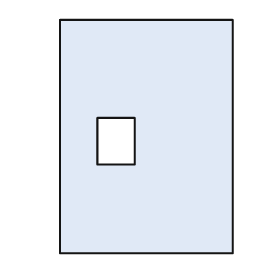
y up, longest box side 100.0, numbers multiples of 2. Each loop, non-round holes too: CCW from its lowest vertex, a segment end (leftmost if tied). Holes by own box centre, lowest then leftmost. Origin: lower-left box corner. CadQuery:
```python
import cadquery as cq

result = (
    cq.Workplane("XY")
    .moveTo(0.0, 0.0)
    .lineTo(74.0, 0.0)
    .lineTo(74.0, 100.0)
    .lineTo(0.0, 100.0)
    .close()
    .moveTo(16.0, 38.0)
    .lineTo(32.0, 38.0)
    .lineTo(32.0, 58.0)
    .lineTo(16.0, 58.0)
    .close()
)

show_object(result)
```